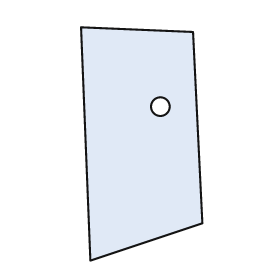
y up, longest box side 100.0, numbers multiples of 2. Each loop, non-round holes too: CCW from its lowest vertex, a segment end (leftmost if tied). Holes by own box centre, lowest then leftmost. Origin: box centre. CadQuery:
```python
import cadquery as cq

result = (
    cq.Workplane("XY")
    .moveTo(-22.0, -50.0)
    .lineTo(26.0, -34.0)
    .lineTo(22.0, 48.0)
    .lineTo(-26.0, 50.0)
    .close()
    .moveTo(8.0, 16.0)
    .circle(4.0)
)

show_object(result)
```